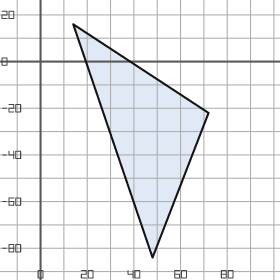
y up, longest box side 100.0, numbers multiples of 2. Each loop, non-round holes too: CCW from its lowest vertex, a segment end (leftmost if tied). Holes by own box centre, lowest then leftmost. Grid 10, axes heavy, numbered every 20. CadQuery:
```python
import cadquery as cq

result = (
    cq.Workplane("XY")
    .moveTo(48.0, -84.0)
    .lineTo(72.0, -22.0)
    .lineTo(14.0, 16.0)
    .close()
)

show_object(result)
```